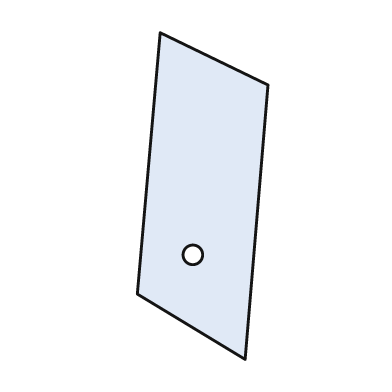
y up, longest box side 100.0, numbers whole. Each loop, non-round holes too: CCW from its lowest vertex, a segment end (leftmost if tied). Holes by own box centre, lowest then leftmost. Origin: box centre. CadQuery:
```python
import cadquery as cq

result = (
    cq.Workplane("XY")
    .moveTo(13.0, -50.0)
    .lineTo(20.0, 34.0)
    .lineTo(-13.0, 50.0)
    .lineTo(-20.0, -30.0)
    .close()
    .moveTo(-3.0, -18.0)
    .circle(3.0)
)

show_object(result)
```